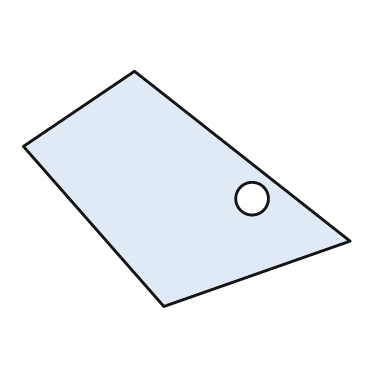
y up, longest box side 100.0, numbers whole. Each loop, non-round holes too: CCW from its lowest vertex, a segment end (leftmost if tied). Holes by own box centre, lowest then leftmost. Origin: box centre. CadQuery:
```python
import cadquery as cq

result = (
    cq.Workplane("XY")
    .moveTo(-7.0, -36.0)
    .lineTo(50.0, -16.0)
    .lineTo(-16.0, 36.0)
    .lineTo(-50.0, 13.0)
    .close()
    .moveTo(20.0, -3.0)
    .circle(5.0)
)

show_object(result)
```